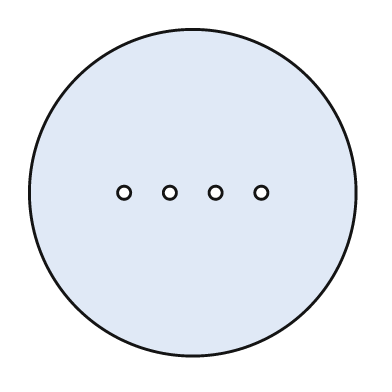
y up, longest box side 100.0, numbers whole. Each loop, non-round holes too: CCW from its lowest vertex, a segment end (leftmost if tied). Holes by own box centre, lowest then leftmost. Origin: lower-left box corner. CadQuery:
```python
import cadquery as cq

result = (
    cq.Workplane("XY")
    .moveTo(50.0, 50.0)
    .circle(50.0)
    .moveTo(29.0, 50.0)
    .circle(2.0)
    .moveTo(43.0, 50.0)
    .circle(2.0)
    .moveTo(57.0, 50.0)
    .circle(2.0)
    .moveTo(71.0, 50.0)
    .circle(2.0)
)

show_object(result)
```